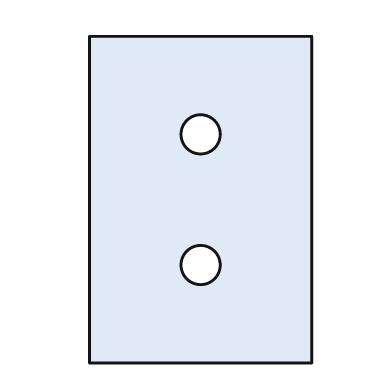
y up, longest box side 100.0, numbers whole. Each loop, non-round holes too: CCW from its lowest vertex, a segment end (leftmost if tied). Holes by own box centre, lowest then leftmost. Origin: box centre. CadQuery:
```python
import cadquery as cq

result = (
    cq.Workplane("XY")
    .moveTo(-34.0, -50.0)
    .lineTo(34.0, -50.0)
    .lineTo(34.0, 50.0)
    .lineTo(-34.0, 50.0)
    .close()
    .moveTo(0.0, -20.0)
    .circle(6.0)
    .moveTo(0.0, 20.0)
    .circle(6.0)
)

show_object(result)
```